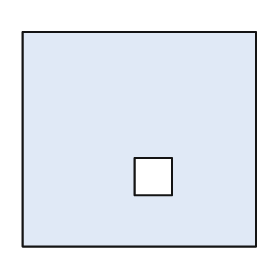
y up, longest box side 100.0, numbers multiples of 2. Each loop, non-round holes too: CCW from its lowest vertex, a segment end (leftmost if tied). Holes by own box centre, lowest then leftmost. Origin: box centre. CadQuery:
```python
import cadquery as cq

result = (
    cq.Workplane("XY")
    .moveTo(-50.0, -46.0)
    .lineTo(50.0, -46.0)
    .lineTo(50.0, 46.0)
    .lineTo(-50.0, 46.0)
    .close()
    .moveTo(-2.0, -24.0)
    .lineTo(14.0, -24.0)
    .lineTo(14.0, -8.0)
    .lineTo(-2.0, -8.0)
    .close()
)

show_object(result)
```